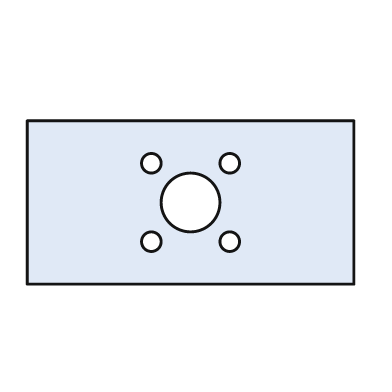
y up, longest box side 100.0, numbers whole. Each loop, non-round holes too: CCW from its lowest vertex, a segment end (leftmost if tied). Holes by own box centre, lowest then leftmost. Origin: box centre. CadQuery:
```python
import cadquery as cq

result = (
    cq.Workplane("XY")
    .moveTo(-50.0, -25.0)
    .lineTo(50.0, -25.0)
    .lineTo(50.0, 25.0)
    .lineTo(-50.0, 25.0)
    .close()
    .moveTo(-12.0, -12.0)
    .circle(3.0)
    .moveTo(12.0, -12.0)
    .circle(3.0)
    .moveTo(0.0, 0.0)
    .circle(9.0)
    .moveTo(-12.0, 12.0)
    .circle(3.0)
    .moveTo(12.0, 12.0)
    .circle(3.0)
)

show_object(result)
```